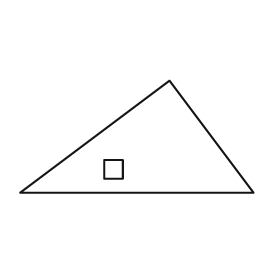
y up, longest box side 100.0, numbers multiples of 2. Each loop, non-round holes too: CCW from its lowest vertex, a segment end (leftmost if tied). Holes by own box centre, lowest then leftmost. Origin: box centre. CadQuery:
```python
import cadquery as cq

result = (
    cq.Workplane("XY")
    .moveTo(-50.0, -24.0)
    .lineTo(50.0, -24.0)
    .lineTo(14.0, 24.0)
    .close()
    .moveTo(-14.0, -18.0)
    .lineTo(-6.0, -18.0)
    .lineTo(-6.0, -10.0)
    .lineTo(-14.0, -10.0)
    .close()
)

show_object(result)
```